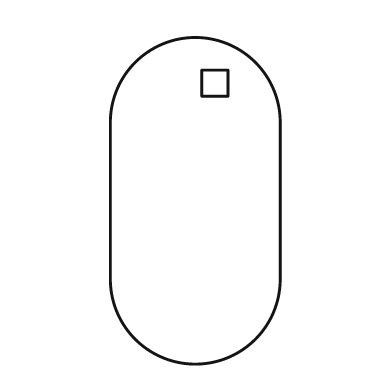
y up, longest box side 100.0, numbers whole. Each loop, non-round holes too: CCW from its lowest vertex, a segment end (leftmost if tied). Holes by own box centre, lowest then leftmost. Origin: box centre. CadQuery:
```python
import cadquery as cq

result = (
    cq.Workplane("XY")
    .moveTo(-26.0, -24.0)
    .threePointArc((0.0, -50.0), (26.0, -24.0))
    .lineTo(26.0, 24.0)
    .threePointArc((0.0, 50.0), (-26.0, 24.0))
    .close()
    .moveTo(2.0, 32.0)
    .lineTo(10.0, 32.0)
    .lineTo(10.0, 40.0)
    .lineTo(2.0, 40.0)
    .close()
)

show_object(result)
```